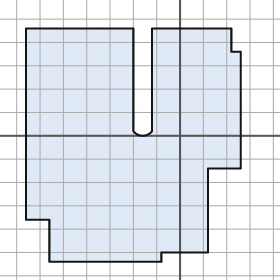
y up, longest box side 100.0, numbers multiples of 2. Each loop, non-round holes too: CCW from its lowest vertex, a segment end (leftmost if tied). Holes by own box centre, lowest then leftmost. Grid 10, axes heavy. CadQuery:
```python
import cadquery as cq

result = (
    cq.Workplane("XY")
    .moveTo(-56.0, -54.0)
    .lineTo(-8.0, -54.0)
    .lineTo(-8.0, -50.0)
    .lineTo(12.0, -50.0)
    .lineTo(12.0, -14.0)
    .lineTo(26.0, -14.0)
    .lineTo(26.0, 36.0)
    .lineTo(22.0, 36.0)
    .lineTo(22.0, 46.0)
    .lineTo(-12.0, 46.0)
    .lineTo(-12.0, 2.0)
    .threePointArc((-16.0, 0.0), (-20.0, 2.0))
    .lineTo(-20.0, 46.0)
    .lineTo(-66.0, 46.0)
    .lineTo(-66.0, -36.0)
    .lineTo(-56.0, -36.0)
    .close()
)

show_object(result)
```